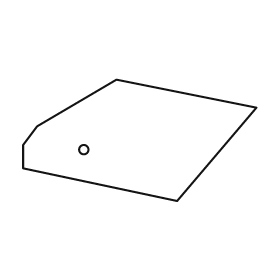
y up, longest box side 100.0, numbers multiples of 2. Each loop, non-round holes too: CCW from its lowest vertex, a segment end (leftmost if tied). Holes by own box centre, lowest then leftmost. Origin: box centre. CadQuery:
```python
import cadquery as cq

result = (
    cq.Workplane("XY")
    .moveTo(16.0, -26.0)
    .lineTo(50.0, 14.0)
    .lineTo(-10.0, 26.0)
    .lineTo(-44.0, 6.0)
    .lineTo(-50.0, -2.0)
    .lineTo(-50.0, -12.0)
    .close()
    .moveTo(-24.0, -4.0)
    .circle(2.0)
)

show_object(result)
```